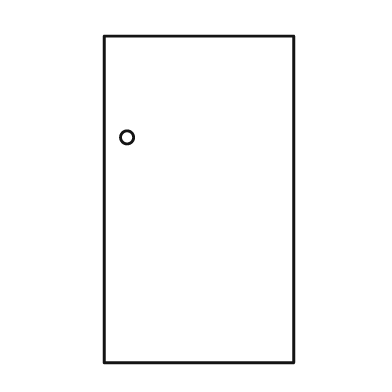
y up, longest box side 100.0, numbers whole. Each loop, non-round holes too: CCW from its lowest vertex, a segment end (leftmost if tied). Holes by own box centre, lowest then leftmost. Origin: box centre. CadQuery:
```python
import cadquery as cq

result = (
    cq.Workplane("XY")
    .moveTo(-29.0, -50.0)
    .lineTo(29.0, -50.0)
    .lineTo(29.0, 50.0)
    .lineTo(-29.0, 50.0)
    .close()
    .moveTo(-22.0, 19.0)
    .circle(2.0)
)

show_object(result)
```